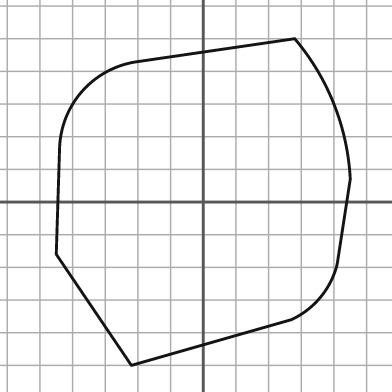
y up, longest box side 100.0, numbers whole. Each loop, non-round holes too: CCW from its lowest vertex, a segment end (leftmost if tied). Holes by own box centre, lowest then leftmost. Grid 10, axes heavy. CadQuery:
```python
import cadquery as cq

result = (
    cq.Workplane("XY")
    .moveTo(-22.0, -50.0)
    .lineTo(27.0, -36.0)
    .threePointArc((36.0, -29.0), (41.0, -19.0))
    .lineTo(45.0, 7.0)
    .threePointArc((40.0, 30.0), (28.0, 50.0))
    .lineTo(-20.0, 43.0)
    .threePointArc((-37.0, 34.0), (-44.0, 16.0))
    .lineTo(-45.0, -16.0)
    .close()
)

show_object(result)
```